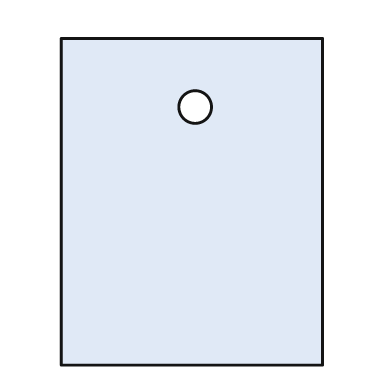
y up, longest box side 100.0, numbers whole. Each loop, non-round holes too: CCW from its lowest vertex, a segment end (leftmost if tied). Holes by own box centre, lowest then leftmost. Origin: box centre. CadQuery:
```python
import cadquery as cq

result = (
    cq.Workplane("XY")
    .moveTo(-40.0, -50.0)
    .lineTo(40.0, -50.0)
    .lineTo(40.0, 50.0)
    .lineTo(-40.0, 50.0)
    .close()
    .moveTo(1.0, 29.0)
    .circle(5.0)
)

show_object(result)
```